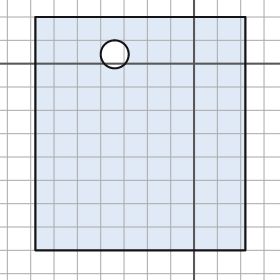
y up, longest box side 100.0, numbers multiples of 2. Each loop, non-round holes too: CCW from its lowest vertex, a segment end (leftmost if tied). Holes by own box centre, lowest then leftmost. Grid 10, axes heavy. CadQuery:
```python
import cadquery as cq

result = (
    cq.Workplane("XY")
    .moveTo(-68.0, -80.0)
    .lineTo(22.0, -80.0)
    .lineTo(22.0, 20.0)
    .lineTo(-68.0, 20.0)
    .close()
    .moveTo(-34.0, 4.0)
    .circle(6.0)
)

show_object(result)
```